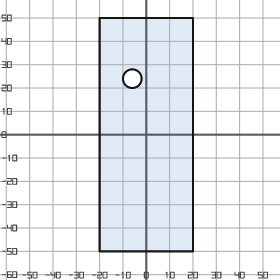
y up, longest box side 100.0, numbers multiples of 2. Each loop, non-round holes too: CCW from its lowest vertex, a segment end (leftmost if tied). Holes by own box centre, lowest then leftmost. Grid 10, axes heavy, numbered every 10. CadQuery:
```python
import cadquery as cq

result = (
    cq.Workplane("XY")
    .moveTo(-20.0, -50.0)
    .lineTo(20.0, -50.0)
    .lineTo(20.0, 50.0)
    .lineTo(-20.0, 50.0)
    .close()
    .moveTo(-6.0, 24.0)
    .circle(4.0)
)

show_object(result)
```